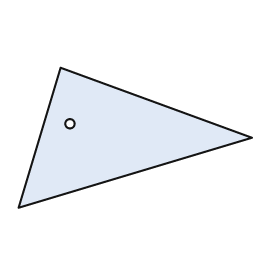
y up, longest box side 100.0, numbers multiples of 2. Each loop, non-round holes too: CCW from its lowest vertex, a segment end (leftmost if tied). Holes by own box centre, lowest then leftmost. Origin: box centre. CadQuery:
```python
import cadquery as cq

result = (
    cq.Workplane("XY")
    .moveTo(-50.0, -30.0)
    .lineTo(50.0, 0.0)
    .lineTo(-32.0, 30.0)
    .close()
    .moveTo(-28.0, 6.0)
    .circle(2.0)
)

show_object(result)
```